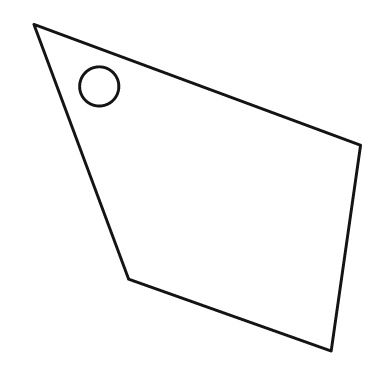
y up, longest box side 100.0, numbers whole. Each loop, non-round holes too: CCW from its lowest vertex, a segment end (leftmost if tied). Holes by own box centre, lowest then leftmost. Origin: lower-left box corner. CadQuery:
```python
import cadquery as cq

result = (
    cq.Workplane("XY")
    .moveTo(91.0, 0.0)
    .lineTo(100.0, 63.0)
    .lineTo(0.0, 100.0)
    .lineTo(29.0, 22.0)
    .close()
    .moveTo(20.0, 81.0)
    .circle(6.0)
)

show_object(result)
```